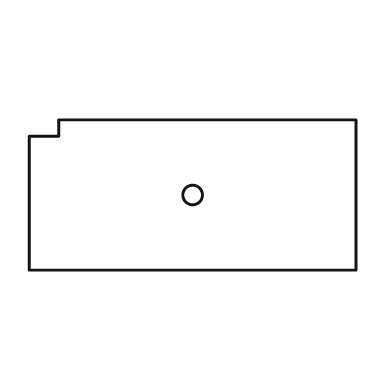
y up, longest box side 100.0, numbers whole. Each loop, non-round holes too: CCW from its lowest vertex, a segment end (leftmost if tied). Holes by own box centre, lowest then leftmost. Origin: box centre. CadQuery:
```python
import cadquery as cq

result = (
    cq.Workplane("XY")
    .moveTo(-50.0, -23.0)
    .lineTo(50.0, -23.0)
    .lineTo(50.0, 23.0)
    .lineTo(-41.0, 23.0)
    .lineTo(-41.0, 18.0)
    .lineTo(-50.0, 18.0)
    .close()
    .moveTo(0.0, 0.0)
    .circle(3.0)
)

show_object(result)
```